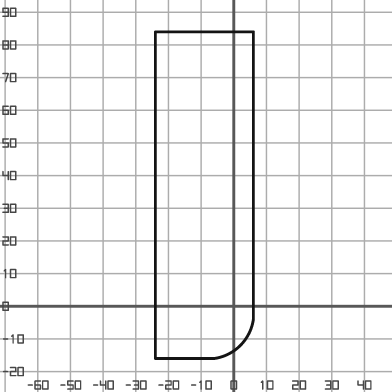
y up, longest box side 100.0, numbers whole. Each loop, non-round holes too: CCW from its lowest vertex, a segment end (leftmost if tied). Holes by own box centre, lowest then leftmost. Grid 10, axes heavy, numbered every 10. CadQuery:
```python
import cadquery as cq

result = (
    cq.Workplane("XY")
    .moveTo(-24.0, -16.0)
    .lineTo(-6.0, -16.0)
    .threePointArc((2.0, -12.0), (6.0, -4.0))
    .lineTo(6.0, 84.0)
    .lineTo(-24.0, 84.0)
    .close()
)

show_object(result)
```